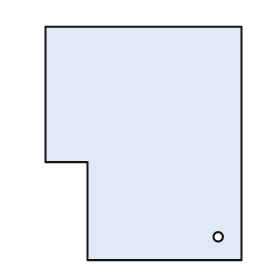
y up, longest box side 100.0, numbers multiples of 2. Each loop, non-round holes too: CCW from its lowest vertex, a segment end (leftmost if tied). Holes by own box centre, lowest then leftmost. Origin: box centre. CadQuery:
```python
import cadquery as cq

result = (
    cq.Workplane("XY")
    .moveTo(-24.0, -50.0)
    .lineTo(42.0, -50.0)
    .lineTo(42.0, 50.0)
    .lineTo(-42.0, 50.0)
    .lineTo(-42.0, -8.0)
    .lineTo(-24.0, -8.0)
    .close()
    .moveTo(32.0, -40.0)
    .circle(2.0)
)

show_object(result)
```